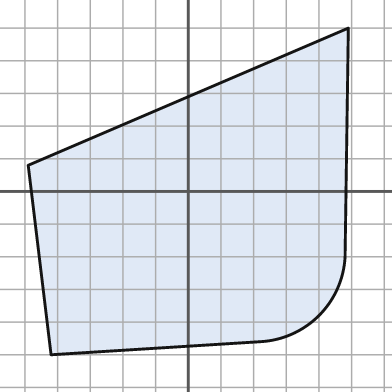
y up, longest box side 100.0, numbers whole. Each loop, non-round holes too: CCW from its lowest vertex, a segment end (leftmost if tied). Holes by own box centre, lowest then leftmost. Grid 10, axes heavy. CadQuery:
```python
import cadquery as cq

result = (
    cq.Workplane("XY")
    .moveTo(-42.0, -50.0)
    .lineTo(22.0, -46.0)
    .threePointArc((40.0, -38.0), (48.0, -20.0))
    .lineTo(49.0, 50.0)
    .lineTo(-49.0, 8.0)
    .close()
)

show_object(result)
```